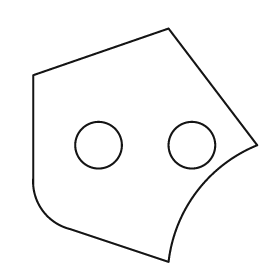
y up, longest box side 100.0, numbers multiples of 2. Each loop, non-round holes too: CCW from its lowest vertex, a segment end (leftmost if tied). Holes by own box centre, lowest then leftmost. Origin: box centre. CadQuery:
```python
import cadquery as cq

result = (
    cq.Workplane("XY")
    .moveTo(10.0, -50.0)
    .threePointArc((22.0, -20.0), (48.0, 0.0))
    .lineTo(10.0, 50.0)
    .lineTo(-48.0, 30.0)
    .lineTo(-48.0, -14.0)
    .threePointArc((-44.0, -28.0), (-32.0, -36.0))
    .close()
    .moveTo(-20.0, 0.0)
    .circle(10.0)
    .moveTo(20.0, 0.0)
    .circle(10.0)
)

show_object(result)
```